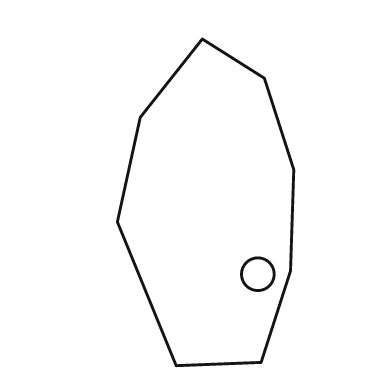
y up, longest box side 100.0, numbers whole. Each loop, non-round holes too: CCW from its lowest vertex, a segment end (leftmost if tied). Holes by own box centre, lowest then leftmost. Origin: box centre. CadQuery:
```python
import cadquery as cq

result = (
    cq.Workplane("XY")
    .moveTo(-9.0, -50.0)
    .lineTo(17.0, -49.0)
    .lineTo(26.0, -21.0)
    .lineTo(27.0, 10.0)
    .lineTo(18.0, 38.0)
    .lineTo(-1.0, 50.0)
    .lineTo(-20.0, 26.0)
    .lineTo(-27.0, -6.0)
    .close()
    .moveTo(16.0, -22.0)
    .circle(5.0)
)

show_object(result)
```